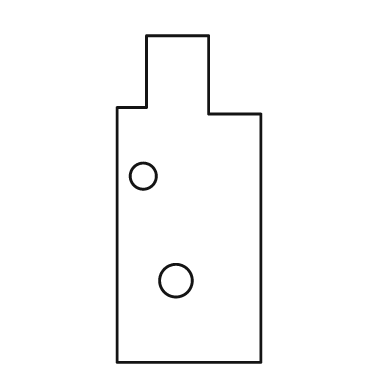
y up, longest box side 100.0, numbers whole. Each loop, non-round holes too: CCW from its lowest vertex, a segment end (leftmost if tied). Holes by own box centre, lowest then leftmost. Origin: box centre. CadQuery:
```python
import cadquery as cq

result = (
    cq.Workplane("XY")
    .moveTo(-22.0, -50.0)
    .lineTo(22.0, -50.0)
    .lineTo(22.0, 26.0)
    .lineTo(6.0, 26.0)
    .lineTo(6.0, 50.0)
    .lineTo(-13.0, 50.0)
    .lineTo(-13.0, 28.0)
    .lineTo(-22.0, 28.0)
    .close()
    .moveTo(-4.0, -25.0)
    .circle(5.0)
    .moveTo(-14.0, 7.0)
    .circle(4.0)
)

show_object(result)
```